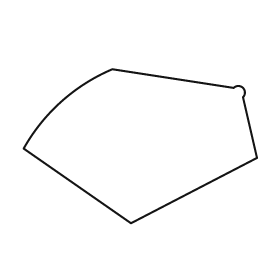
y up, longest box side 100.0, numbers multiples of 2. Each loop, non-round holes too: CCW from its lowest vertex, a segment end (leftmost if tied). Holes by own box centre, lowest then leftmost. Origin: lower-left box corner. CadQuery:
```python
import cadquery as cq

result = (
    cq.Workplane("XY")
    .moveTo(46.0, 0.0)
    .lineTo(100.0, 28.0)
    .lineTo(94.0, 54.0)
    .threePointArc((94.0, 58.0), (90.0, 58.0))
    .lineTo(38.0, 66.0)
    .threePointArc((16.0, 52.0), (0.0, 32.0))
    .close()
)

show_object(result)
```